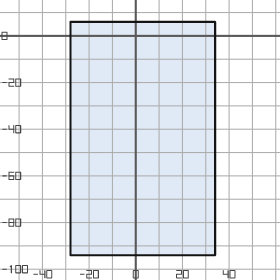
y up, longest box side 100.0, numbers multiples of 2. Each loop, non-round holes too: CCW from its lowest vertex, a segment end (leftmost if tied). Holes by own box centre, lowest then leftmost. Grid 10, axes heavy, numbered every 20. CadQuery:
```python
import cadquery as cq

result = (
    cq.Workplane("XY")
    .moveTo(-28.0, -94.0)
    .lineTo(34.0, -94.0)
    .lineTo(34.0, 6.0)
    .lineTo(-28.0, 6.0)
    .close()
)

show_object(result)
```